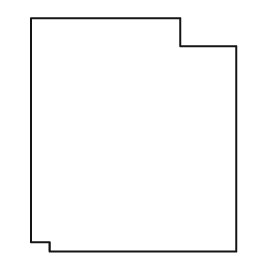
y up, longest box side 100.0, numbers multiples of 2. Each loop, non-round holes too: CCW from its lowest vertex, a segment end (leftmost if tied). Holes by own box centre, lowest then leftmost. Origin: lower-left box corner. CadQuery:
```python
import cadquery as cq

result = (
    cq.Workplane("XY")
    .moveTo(8.0, 0.0)
    .lineTo(88.0, 0.0)
    .lineTo(88.0, 88.0)
    .lineTo(64.0, 88.0)
    .lineTo(64.0, 100.0)
    .lineTo(0.0, 100.0)
    .lineTo(0.0, 4.0)
    .lineTo(8.0, 4.0)
    .close()
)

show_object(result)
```